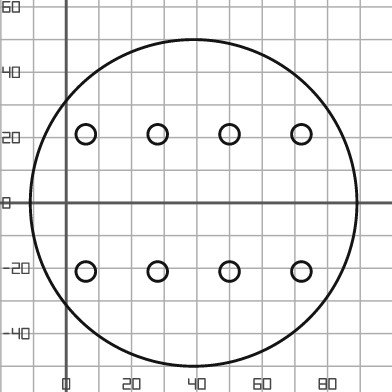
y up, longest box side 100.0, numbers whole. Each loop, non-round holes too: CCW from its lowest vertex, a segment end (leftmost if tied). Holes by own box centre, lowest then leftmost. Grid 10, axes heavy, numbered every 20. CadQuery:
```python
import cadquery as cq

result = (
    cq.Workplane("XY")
    .moveTo(39.0, 0.0)
    .circle(50.0)
    .moveTo(6.0, -21.0)
    .circle(3.0)
    .moveTo(28.0, -21.0)
    .circle(3.0)
    .moveTo(50.0, -21.0)
    .circle(3.0)
    .moveTo(72.0, -21.0)
    .circle(3.0)
    .moveTo(6.0, 21.0)
    .circle(3.0)
    .moveTo(28.0, 21.0)
    .circle(3.0)
    .moveTo(50.0, 21.0)
    .circle(3.0)
    .moveTo(72.0, 21.0)
    .circle(3.0)
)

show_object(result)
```